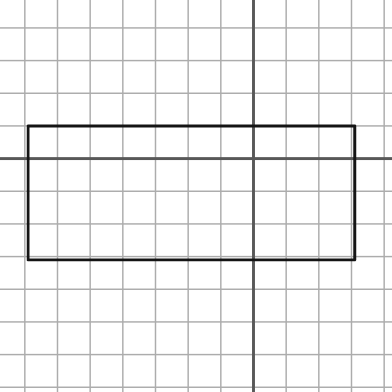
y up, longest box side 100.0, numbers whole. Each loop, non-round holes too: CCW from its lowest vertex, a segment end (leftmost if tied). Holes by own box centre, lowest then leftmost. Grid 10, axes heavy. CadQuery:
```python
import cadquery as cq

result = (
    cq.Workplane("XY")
    .moveTo(-69.0, -31.0)
    .lineTo(31.0, -31.0)
    .lineTo(31.0, 10.0)
    .lineTo(-69.0, 10.0)
    .close()
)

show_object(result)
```